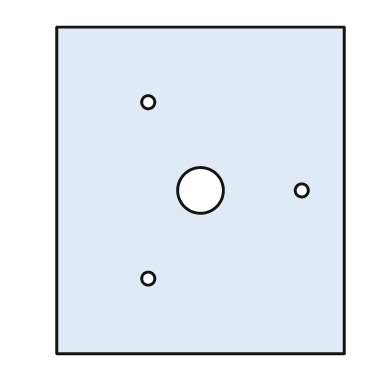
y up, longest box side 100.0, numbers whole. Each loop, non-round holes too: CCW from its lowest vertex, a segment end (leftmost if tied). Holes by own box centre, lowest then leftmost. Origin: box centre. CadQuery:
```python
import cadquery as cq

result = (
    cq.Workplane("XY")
    .moveTo(-44.0, -50.0)
    .lineTo(44.0, -50.0)
    .lineTo(44.0, 50.0)
    .lineTo(-44.0, 50.0)
    .close()
    .moveTo(-16.0, -27.0)
    .circle(2.0)
    .moveTo(0.0, 0.0)
    .circle(7.0)
    .moveTo(31.0, 0.0)
    .circle(2.0)
    .moveTo(-16.0, 27.0)
    .circle(2.0)
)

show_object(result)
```